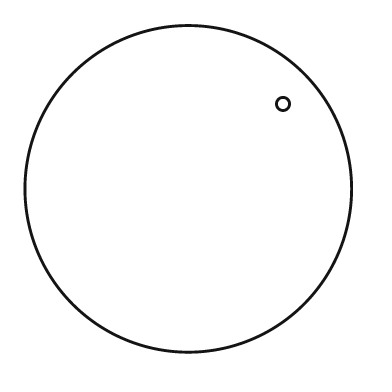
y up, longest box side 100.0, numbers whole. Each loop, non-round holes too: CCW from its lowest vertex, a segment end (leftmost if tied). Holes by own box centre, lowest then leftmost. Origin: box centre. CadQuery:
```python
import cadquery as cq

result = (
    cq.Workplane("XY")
    .moveTo(0.0, 0.0)
    .circle(50.0)
    .moveTo(29.0, 26.0)
    .circle(2.0)
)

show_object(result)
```